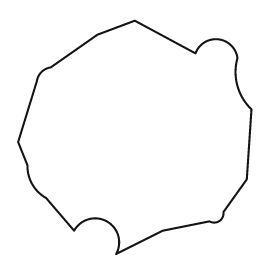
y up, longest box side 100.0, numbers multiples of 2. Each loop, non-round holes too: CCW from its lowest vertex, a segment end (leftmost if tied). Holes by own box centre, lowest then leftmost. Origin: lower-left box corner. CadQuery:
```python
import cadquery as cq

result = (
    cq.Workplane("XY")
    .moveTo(42.0, 0.0)
    .lineTo(62.0, 10.0)
    .lineTo(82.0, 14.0)
    .threePointArc((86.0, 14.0), (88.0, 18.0))
    .lineTo(98.0, 32.0)
    .lineTo(100.0, 62.0)
    .threePointArc((94.0, 72.0), (94.0, 84.0))
    .threePointArc((86.0, 92.0), (76.0, 86.0))
    .lineTo(50.0, 100.0)
    .lineTo(34.0, 94.0)
    .lineTo(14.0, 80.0)
    .threePointArc((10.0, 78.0), (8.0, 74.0))
    .lineTo(0.0, 48.0)
    .lineTo(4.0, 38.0)
    .threePointArc((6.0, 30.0), (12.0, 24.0))
    .lineTo(24.0, 10.0)
    .threePointArc((38.0, 14.0), (42.0, 0.0))
    .close()
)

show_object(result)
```